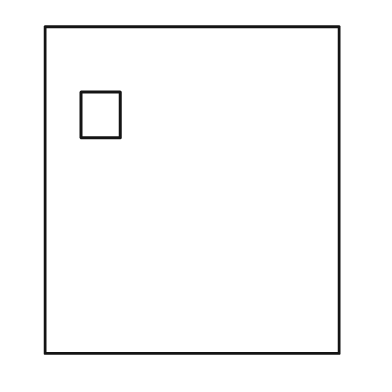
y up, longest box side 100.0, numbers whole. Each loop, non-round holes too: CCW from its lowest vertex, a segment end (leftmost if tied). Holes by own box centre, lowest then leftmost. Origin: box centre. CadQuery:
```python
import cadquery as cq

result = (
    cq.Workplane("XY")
    .moveTo(-45.0, -50.0)
    .lineTo(45.0, -50.0)
    .lineTo(45.0, 50.0)
    .lineTo(-45.0, 50.0)
    .close()
    .moveTo(-34.0, 16.0)
    .lineTo(-22.0, 16.0)
    .lineTo(-22.0, 30.0)
    .lineTo(-34.0, 30.0)
    .close()
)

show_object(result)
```